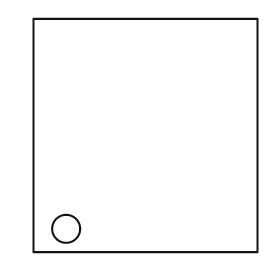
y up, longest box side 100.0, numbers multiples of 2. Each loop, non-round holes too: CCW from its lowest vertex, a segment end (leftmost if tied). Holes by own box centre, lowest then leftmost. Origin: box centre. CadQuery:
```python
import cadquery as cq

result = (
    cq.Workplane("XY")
    .moveTo(-48.0, -50.0)
    .lineTo(48.0, -50.0)
    .lineTo(48.0, 50.0)
    .lineTo(-48.0, 50.0)
    .close()
    .moveTo(-34.0, -40.0)
    .circle(6.0)
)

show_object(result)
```